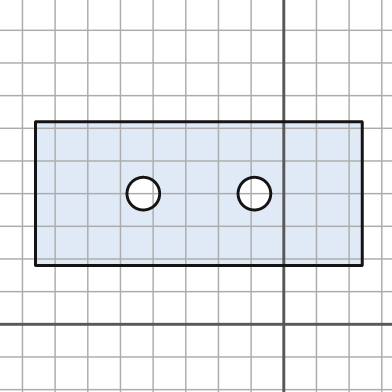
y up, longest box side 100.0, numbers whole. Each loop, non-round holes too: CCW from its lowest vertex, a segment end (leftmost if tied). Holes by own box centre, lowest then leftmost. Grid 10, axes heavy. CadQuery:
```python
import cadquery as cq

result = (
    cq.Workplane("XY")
    .moveTo(-76.0, 18.0)
    .lineTo(24.0, 18.0)
    .lineTo(24.0, 62.0)
    .lineTo(-76.0, 62.0)
    .close()
    .moveTo(-43.0, 40.0)
    .circle(5.0)
    .moveTo(-9.0, 40.0)
    .circle(5.0)
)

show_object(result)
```